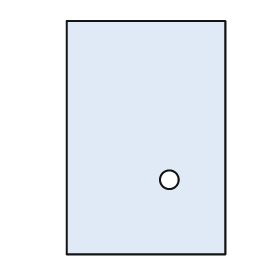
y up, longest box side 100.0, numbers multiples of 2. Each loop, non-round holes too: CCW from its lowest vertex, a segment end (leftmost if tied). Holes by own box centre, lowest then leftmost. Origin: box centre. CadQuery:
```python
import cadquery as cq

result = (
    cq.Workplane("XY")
    .moveTo(-34.0, -50.0)
    .lineTo(34.0, -50.0)
    .lineTo(34.0, 50.0)
    .lineTo(-34.0, 50.0)
    .close()
    .moveTo(10.0, -18.0)
    .circle(4.0)
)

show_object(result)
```